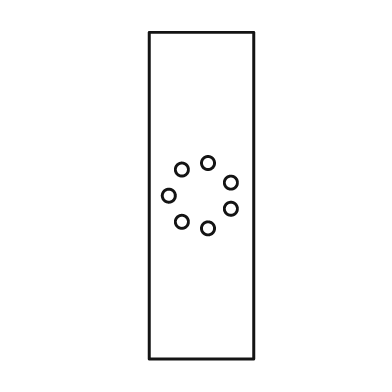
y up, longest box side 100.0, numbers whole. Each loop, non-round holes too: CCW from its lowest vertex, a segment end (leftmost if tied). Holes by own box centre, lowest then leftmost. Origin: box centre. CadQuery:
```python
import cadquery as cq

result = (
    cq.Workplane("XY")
    .moveTo(-16.0, -50.0)
    .lineTo(16.0, -50.0)
    .lineTo(16.0, 50.0)
    .lineTo(-16.0, 50.0)
    .close()
    .moveTo(2.0, -10.0)
    .circle(2.0)
    .moveTo(-6.0, -8.0)
    .circle(2.0)
    .moveTo(9.0, -4.0)
    .circle(2.0)
    .moveTo(-10.0, 0.0)
    .circle(2.0)
    .moveTo(9.0, 4.0)
    .circle(2.0)
    .moveTo(-6.0, 8.0)
    .circle(2.0)
    .moveTo(2.0, 10.0)
    .circle(2.0)
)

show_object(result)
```